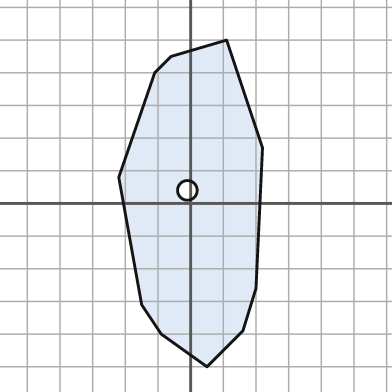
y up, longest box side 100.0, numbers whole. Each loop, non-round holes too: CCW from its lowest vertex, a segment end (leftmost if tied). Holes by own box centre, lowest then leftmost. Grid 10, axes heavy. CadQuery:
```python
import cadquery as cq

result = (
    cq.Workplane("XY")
    .moveTo(5.0, -50.0)
    .lineTo(16.0, -39.0)
    .lineTo(20.0, -26.0)
    .lineTo(22.0, 17.0)
    .lineTo(11.0, 50.0)
    .lineTo(-6.0, 45.0)
    .lineTo(-11.0, 40.0)
    .lineTo(-22.0, 8.0)
    .lineTo(-15.0, -31.0)
    .lineTo(-9.0, -40.0)
    .close()
    .moveTo(-1.0, 4.0)
    .circle(3.0)
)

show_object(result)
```